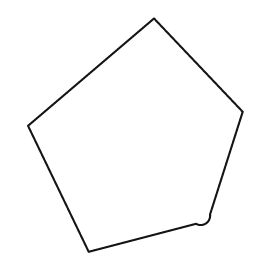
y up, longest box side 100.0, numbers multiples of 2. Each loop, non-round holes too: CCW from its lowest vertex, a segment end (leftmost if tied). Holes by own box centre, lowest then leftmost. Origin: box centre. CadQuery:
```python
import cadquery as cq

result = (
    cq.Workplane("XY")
    .moveTo(-20.0, -50.0)
    .lineTo(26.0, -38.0)
    .threePointArc((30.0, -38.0), (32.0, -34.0))
    .lineTo(46.0, 10.0)
    .lineTo(8.0, 50.0)
    .lineTo(-46.0, 4.0)
    .close()
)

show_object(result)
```